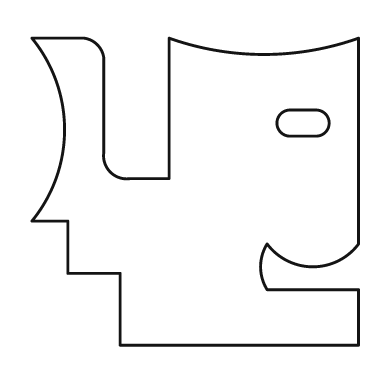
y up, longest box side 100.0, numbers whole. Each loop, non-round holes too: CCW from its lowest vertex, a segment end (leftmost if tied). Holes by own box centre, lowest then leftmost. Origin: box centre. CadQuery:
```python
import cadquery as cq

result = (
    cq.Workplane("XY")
    .moveTo(-23.0, -47.0)
    .lineTo(50.0, -47.0)
    .lineTo(50.0, -30.0)
    .lineTo(22.0, -30.0)
    .threePointArc((20.0, -23.0), (22.0, -16.0))
    .threePointArc((36.0, -23.0), (50.0, -16.0))
    .lineTo(50.0, 47.0)
    .threePointArc((21.0, 42.0), (-8.0, 47.0))
    .lineTo(-8.0, 4.0)
    .lineTo(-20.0, 4.0)
    .threePointArc((-26.0, 6.0), (-28.0, 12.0))
    .lineTo(-28.0, 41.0)
    .threePointArc((-30.0, 45.0), (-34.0, 47.0))
    .lineTo(-50.0, 47.0)
    .threePointArc((-40.0, 19.0), (-50.0, -9.0))
    .lineTo(-39.0, -9.0)
    .lineTo(-39.0, -25.0)
    .lineTo(-23.0, -25.0)
    .close()
    .moveTo(29.0, 17.0)
    .lineTo(37.0, 17.0)
    .threePointArc((41.0, 21.0), (37.0, 25.0))
    .lineTo(29.0, 25.0)
    .threePointArc((25.0, 21.0), (29.0, 17.0))
    .close()
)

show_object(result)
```